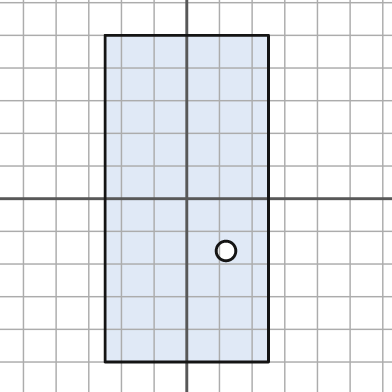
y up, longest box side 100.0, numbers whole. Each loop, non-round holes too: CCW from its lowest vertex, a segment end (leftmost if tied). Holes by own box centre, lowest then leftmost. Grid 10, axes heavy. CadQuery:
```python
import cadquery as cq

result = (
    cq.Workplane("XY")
    .moveTo(-25.0, -50.0)
    .lineTo(25.0, -50.0)
    .lineTo(25.0, 50.0)
    .lineTo(-25.0, 50.0)
    .close()
    .moveTo(12.0, -16.0)
    .circle(3.0)
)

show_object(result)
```